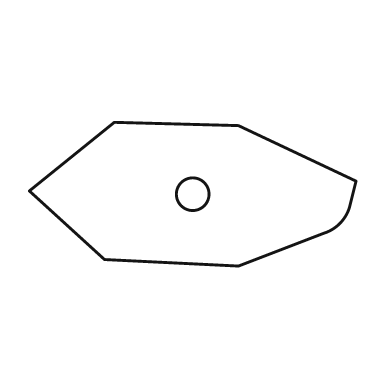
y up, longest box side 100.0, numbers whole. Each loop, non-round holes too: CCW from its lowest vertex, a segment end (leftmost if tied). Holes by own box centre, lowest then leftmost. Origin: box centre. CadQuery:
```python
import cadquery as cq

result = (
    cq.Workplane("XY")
    .moveTo(14.0, -22.0)
    .lineTo(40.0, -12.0)
    .threePointArc((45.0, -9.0), (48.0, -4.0))
    .lineTo(50.0, 4.0)
    .lineTo(14.0, 21.0)
    .lineTo(-24.0, 22.0)
    .lineTo(-50.0, 1.0)
    .lineTo(-27.0, -20.0)
    .close()
    .moveTo(0.0, 0.0)
    .circle(5.0)
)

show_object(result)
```